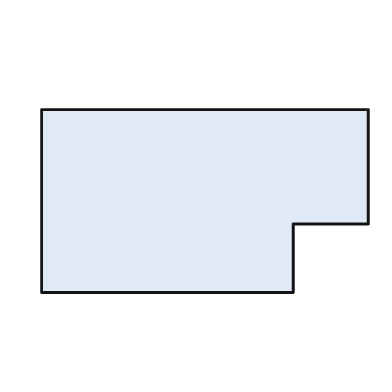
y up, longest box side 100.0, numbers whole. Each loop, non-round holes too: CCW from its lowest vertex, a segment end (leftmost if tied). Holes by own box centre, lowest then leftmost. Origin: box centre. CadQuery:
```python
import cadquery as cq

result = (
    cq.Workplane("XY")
    .moveTo(-50.0, -28.0)
    .lineTo(27.0, -28.0)
    .lineTo(27.0, -7.0)
    .lineTo(50.0, -7.0)
    .lineTo(50.0, 28.0)
    .lineTo(-50.0, 28.0)
    .close()
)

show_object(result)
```